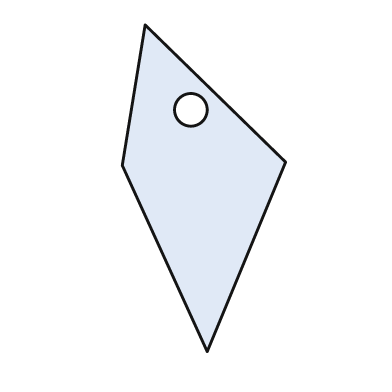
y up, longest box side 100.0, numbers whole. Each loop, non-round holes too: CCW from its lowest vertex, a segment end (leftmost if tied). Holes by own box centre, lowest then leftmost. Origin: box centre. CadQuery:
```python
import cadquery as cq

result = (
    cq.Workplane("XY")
    .moveTo(1.0, -50.0)
    .lineTo(25.0, 8.0)
    .lineTo(-18.0, 50.0)
    .lineTo(-25.0, 7.0)
    .close()
    .moveTo(-4.0, 24.0)
    .circle(5.0)
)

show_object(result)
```